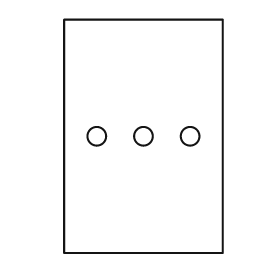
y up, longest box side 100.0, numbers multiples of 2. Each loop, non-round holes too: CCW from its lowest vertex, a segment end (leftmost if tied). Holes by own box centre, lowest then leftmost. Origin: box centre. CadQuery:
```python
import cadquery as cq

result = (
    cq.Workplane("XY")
    .moveTo(-34.0, -50.0)
    .lineTo(34.0, -50.0)
    .lineTo(34.0, 50.0)
    .lineTo(-34.0, 50.0)
    .close()
    .moveTo(-20.0, 0.0)
    .circle(4.0)
    .moveTo(0.0, 0.0)
    .circle(4.0)
    .moveTo(20.0, 0.0)
    .circle(4.0)
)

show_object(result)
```